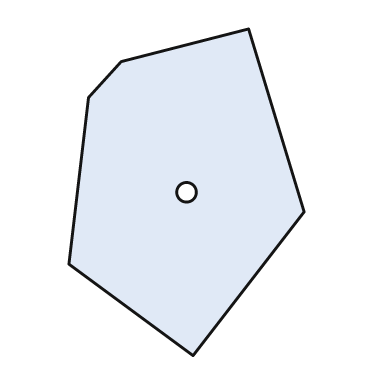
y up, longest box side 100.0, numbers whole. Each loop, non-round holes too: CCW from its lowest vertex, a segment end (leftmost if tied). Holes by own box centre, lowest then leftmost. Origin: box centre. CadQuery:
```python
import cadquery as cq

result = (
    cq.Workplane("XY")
    .moveTo(2.0, -50.0)
    .lineTo(36.0, -6.0)
    .lineTo(19.0, 50.0)
    .lineTo(-20.0, 40.0)
    .lineTo(-30.0, 29.0)
    .lineTo(-36.0, -22.0)
    .close()
    .moveTo(0.0, 0.0)
    .circle(3.0)
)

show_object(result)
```